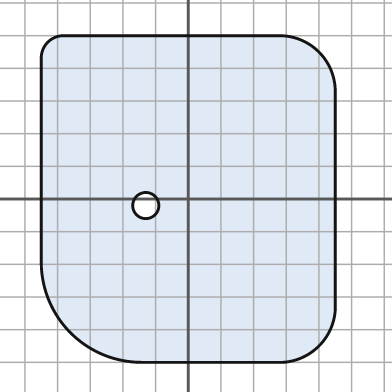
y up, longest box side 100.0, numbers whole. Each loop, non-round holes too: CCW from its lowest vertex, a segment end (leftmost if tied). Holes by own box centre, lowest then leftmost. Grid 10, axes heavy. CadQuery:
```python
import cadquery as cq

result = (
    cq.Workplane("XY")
    .moveTo(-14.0, -50.0)
    .lineTo(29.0, -50.0)
    .threePointArc((40.0, -45.0), (45.0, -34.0))
    .lineTo(45.0, 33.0)
    .threePointArc((40.0, 45.0), (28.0, 50.0))
    .lineTo(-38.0, 50.0)
    .threePointArc((-43.0, 48.0), (-45.0, 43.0))
    .lineTo(-45.0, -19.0)
    .threePointArc((-36.0, -41.0), (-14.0, -50.0))
    .close()
    .moveTo(-13.0, -2.0)
    .circle(4.0)
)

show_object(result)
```